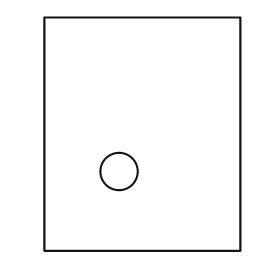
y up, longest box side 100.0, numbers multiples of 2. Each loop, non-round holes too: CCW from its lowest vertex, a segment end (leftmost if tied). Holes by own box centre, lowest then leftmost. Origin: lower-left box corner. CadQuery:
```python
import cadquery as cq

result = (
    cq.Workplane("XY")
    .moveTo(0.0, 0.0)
    .lineTo(84.0, 0.0)
    .lineTo(84.0, 100.0)
    .lineTo(0.0, 100.0)
    .close()
    .moveTo(32.0, 34.0)
    .circle(8.0)
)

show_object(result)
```